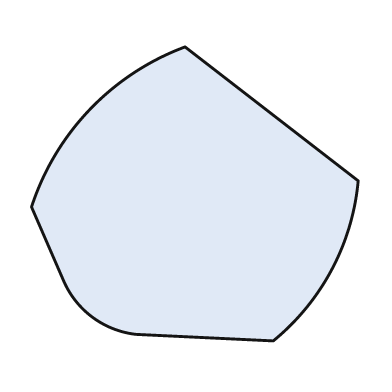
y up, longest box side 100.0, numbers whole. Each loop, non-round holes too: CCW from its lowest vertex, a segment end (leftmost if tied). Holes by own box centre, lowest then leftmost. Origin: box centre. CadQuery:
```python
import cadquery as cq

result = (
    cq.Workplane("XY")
    .moveTo(24.0, -45.0)
    .threePointArc((42.0, -23.0), (50.0, 4.0))
    .lineTo(-3.0, 45.0)
    .threePointArc((-32.0, 26.0), (-50.0, -4.0))
    .lineTo(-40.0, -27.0)
    .threePointArc((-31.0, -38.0), (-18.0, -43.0))
    .close()
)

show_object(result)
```